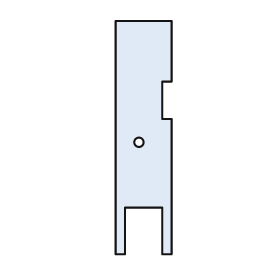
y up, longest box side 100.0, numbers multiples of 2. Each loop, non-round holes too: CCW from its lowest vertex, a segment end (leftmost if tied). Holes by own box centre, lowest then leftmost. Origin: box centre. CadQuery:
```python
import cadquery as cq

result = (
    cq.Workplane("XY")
    .moveTo(-12.0, -50.0)
    .lineTo(-8.0, -50.0)
    .lineTo(-8.0, -30.0)
    .lineTo(8.0, -30.0)
    .lineTo(8.0, -50.0)
    .lineTo(12.0, -50.0)
    .lineTo(12.0, 8.0)
    .lineTo(8.0, 8.0)
    .lineTo(8.0, 24.0)
    .lineTo(12.0, 24.0)
    .lineTo(12.0, 50.0)
    .lineTo(-12.0, 50.0)
    .close()
    .moveTo(-2.0, -2.0)
    .circle(2.0)
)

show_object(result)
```